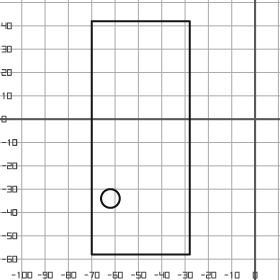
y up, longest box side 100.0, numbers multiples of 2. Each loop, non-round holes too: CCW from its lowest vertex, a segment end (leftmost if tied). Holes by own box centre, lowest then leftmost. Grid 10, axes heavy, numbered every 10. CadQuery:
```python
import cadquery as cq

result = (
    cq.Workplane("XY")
    .moveTo(-70.0, -58.0)
    .lineTo(-28.0, -58.0)
    .lineTo(-28.0, 42.0)
    .lineTo(-70.0, 42.0)
    .close()
    .moveTo(-62.0, -34.0)
    .circle(4.0)
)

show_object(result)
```